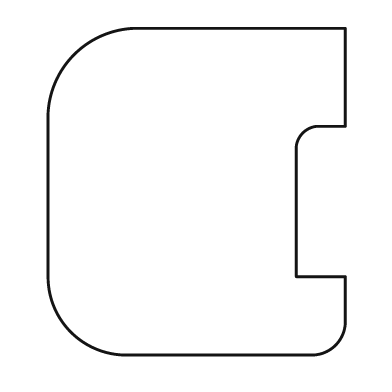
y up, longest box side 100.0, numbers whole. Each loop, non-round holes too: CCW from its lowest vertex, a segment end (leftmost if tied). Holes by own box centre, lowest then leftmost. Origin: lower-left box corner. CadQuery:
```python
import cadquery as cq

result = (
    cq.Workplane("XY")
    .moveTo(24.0, 0.0)
    .lineTo(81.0, 0.0)
    .threePointArc((88.0, 3.0), (91.0, 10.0))
    .lineTo(91.0, 24.0)
    .lineTo(76.0, 24.0)
    .lineTo(76.0, 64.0)
    .threePointArc((78.0, 68.0), (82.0, 70.0))
    .lineTo(91.0, 70.0)
    .lineTo(91.0, 100.0)
    .lineTo(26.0, 100.0)
    .threePointArc((8.0, 92.0), (0.0, 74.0))
    .lineTo(0.0, 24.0)
    .threePointArc((7.0, 7.0), (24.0, 0.0))
    .close()
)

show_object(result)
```